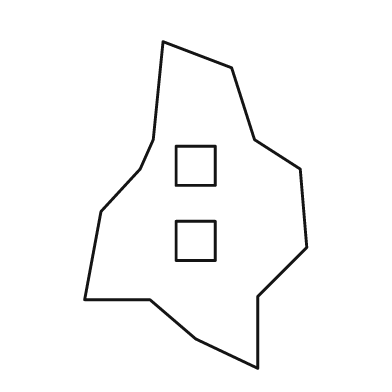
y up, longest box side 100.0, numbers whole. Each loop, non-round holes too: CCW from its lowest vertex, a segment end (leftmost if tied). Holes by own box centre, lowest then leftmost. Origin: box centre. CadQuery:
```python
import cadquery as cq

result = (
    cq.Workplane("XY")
    .moveTo(19.0, -50.0)
    .lineTo(19.0, -28.0)
    .lineTo(34.0, -13.0)
    .lineTo(32.0, 11.0)
    .lineTo(18.0, 20.0)
    .lineTo(11.0, 42.0)
    .lineTo(-10.0, 50.0)
    .lineTo(-13.0, 20.0)
    .lineTo(-17.0, 11.0)
    .lineTo(-29.0, -2.0)
    .lineTo(-34.0, -29.0)
    .lineTo(-14.0, -29.0)
    .lineTo(0.0, -41.0)
    .close()
    .moveTo(-6.0, -17.0)
    .lineTo(6.0, -17.0)
    .lineTo(6.0, -5.0)
    .lineTo(-6.0, -5.0)
    .close()
    .moveTo(-6.0, 6.0)
    .lineTo(6.0, 6.0)
    .lineTo(6.0, 18.0)
    .lineTo(-6.0, 18.0)
    .close()
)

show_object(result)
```